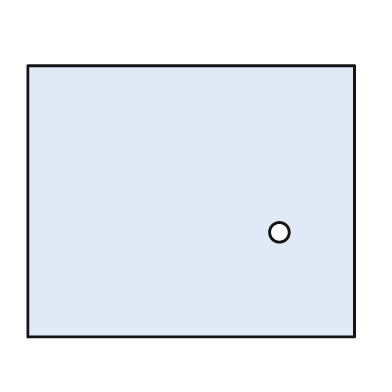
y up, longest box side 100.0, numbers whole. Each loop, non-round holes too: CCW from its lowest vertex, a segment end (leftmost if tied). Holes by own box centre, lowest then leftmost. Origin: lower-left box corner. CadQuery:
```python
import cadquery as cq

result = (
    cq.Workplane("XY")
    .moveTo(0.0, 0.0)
    .lineTo(100.0, 0.0)
    .lineTo(100.0, 83.0)
    .lineTo(0.0, 83.0)
    .close()
    .moveTo(77.0, 32.0)
    .circle(3.0)
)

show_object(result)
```